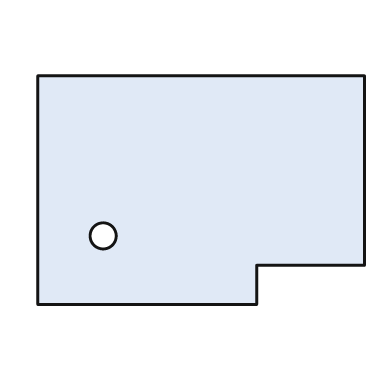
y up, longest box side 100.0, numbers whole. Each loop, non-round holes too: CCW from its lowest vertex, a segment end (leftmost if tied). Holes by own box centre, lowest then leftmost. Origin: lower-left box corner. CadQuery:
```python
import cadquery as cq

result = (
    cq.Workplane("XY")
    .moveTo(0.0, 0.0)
    .lineTo(67.0, 0.0)
    .lineTo(67.0, 12.0)
    .lineTo(100.0, 12.0)
    .lineTo(100.0, 70.0)
    .lineTo(0.0, 70.0)
    .close()
    .moveTo(20.0, 21.0)
    .circle(4.0)
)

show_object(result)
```